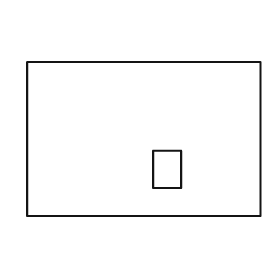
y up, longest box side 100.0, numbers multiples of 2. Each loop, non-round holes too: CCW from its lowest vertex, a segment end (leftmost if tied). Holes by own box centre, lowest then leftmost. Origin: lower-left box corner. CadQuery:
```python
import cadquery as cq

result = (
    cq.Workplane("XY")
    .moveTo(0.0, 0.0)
    .lineTo(100.0, 0.0)
    .lineTo(100.0, 66.0)
    .lineTo(0.0, 66.0)
    .close()
    .moveTo(54.0, 12.0)
    .lineTo(66.0, 12.0)
    .lineTo(66.0, 28.0)
    .lineTo(54.0, 28.0)
    .close()
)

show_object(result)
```